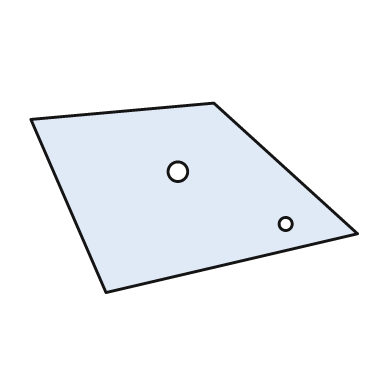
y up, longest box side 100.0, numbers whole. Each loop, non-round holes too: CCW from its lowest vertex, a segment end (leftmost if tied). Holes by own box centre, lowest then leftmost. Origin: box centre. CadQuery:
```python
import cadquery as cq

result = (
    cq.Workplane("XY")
    .moveTo(-27.0, -29.0)
    .lineTo(50.0, -11.0)
    .lineTo(6.0, 29.0)
    .lineTo(-50.0, 24.0)
    .close()
    .moveTo(28.0, -8.0)
    .circle(2.0)
    .moveTo(-5.0, 8.0)
    .circle(3.0)
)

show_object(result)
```